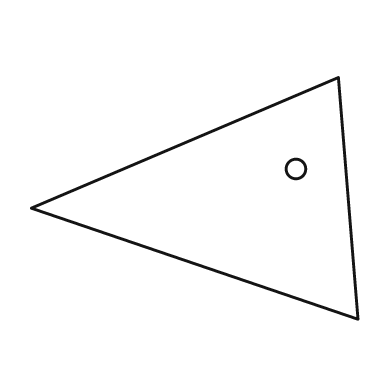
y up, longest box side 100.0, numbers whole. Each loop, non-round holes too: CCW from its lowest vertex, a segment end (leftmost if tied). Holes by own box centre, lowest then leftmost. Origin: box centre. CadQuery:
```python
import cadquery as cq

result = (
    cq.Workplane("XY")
    .moveTo(50.0, -37.0)
    .lineTo(44.0, 37.0)
    .lineTo(-50.0, -3.0)
    .close()
    .moveTo(31.0, 9.0)
    .circle(3.0)
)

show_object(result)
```